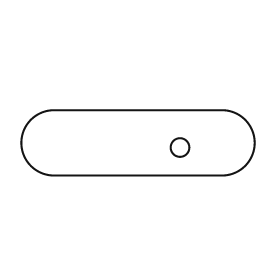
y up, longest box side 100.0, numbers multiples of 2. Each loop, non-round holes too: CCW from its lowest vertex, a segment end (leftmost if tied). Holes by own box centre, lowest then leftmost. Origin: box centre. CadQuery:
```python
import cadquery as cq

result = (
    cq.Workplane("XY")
    .moveTo(-36.0, -14.0)
    .lineTo(36.0, -14.0)
    .threePointArc((50.0, 0.0), (36.0, 14.0))
    .lineTo(-36.0, 14.0)
    .threePointArc((-50.0, 0.0), (-36.0, -14.0))
    .close()
    .moveTo(18.0, -2.0)
    .circle(4.0)
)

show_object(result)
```